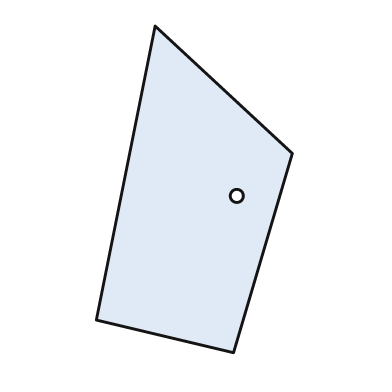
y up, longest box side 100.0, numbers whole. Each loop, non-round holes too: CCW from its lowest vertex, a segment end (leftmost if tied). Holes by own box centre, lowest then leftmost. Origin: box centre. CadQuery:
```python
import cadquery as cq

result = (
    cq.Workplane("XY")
    .moveTo(12.0, -50.0)
    .lineTo(30.0, 11.0)
    .lineTo(-12.0, 50.0)
    .lineTo(-30.0, -40.0)
    .close()
    .moveTo(13.0, -2.0)
    .circle(2.0)
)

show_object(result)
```